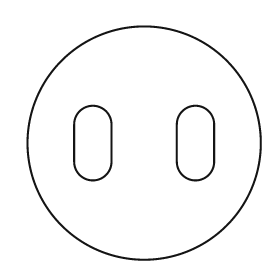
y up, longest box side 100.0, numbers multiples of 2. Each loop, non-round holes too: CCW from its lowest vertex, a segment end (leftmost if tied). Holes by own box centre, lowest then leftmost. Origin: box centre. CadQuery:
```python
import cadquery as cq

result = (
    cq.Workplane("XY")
    .moveTo(0.0, 0.0)
    .circle(50.0)
    .moveTo(-30.0, -8.0)
    .threePointArc((-22.0, -16.0), (-14.0, -8.0))
    .lineTo(-14.0, 8.0)
    .threePointArc((-22.0, 16.0), (-30.0, 8.0))
    .close()
    .moveTo(14.0, -8.0)
    .threePointArc((22.0, -16.0), (30.0, -8.0))
    .lineTo(30.0, 8.0)
    .threePointArc((22.0, 16.0), (14.0, 8.0))
    .close()
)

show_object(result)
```